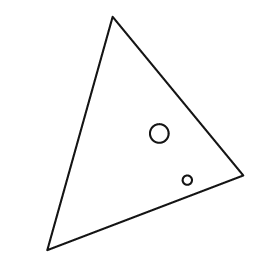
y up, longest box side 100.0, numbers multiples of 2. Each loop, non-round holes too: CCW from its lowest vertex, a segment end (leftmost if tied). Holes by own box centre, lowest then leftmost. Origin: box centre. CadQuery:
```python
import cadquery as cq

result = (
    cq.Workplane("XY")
    .moveTo(-42.0, -50.0)
    .lineTo(42.0, -18.0)
    .lineTo(-14.0, 50.0)
    .close()
    .moveTo(18.0, -20.0)
    .circle(2.0)
    .moveTo(6.0, 0.0)
    .circle(4.0)
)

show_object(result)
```